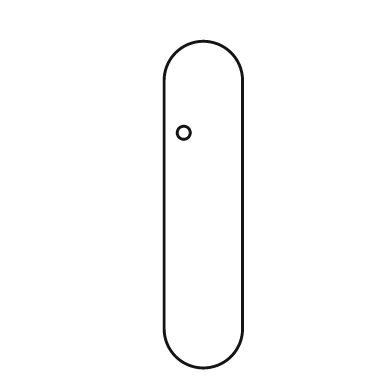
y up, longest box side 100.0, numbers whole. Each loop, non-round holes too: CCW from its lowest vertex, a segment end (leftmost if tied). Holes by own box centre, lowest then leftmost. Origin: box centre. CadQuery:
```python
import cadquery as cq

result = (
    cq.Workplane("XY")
    .moveTo(-12.0, -38.0)
    .threePointArc((0.0, -50.0), (12.0, -38.0))
    .lineTo(12.0, 38.0)
    .threePointArc((0.0, 50.0), (-12.0, 38.0))
    .close()
    .moveTo(-6.0, 22.0)
    .circle(2.0)
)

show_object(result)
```